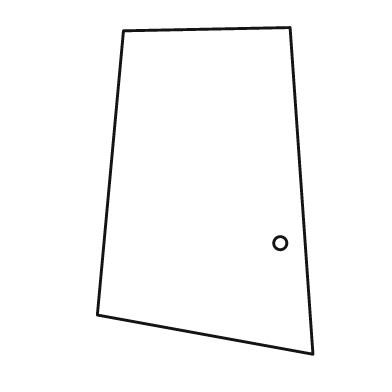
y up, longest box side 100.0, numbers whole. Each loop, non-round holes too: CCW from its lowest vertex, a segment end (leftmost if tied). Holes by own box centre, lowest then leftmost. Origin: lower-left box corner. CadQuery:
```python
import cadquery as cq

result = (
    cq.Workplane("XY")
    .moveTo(66.0, 0.0)
    .lineTo(59.0, 100.0)
    .lineTo(8.0, 99.0)
    .lineTo(0.0, 12.0)
    .close()
    .moveTo(56.0, 34.0)
    .circle(2.0)
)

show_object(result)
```